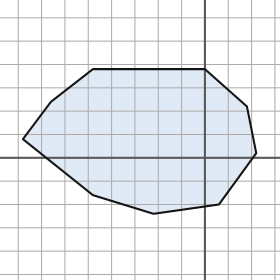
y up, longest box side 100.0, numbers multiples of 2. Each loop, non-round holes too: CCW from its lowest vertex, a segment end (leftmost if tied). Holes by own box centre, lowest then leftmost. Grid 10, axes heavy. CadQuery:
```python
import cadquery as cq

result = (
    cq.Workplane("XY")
    .moveTo(-22.0, -24.0)
    .lineTo(6.0, -20.0)
    .lineTo(22.0, 2.0)
    .lineTo(18.0, 22.0)
    .lineTo(0.0, 38.0)
    .lineTo(-48.0, 38.0)
    .lineTo(-66.0, 24.0)
    .lineTo(-78.0, 8.0)
    .lineTo(-48.0, -16.0)
    .close()
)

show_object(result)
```